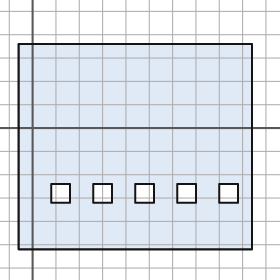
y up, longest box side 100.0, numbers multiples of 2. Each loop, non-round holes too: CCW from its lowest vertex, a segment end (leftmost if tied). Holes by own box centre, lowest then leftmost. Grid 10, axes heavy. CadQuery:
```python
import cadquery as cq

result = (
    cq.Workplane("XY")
    .moveTo(-6.0, -52.0)
    .lineTo(94.0, -52.0)
    .lineTo(94.0, 36.0)
    .lineTo(-6.0, 36.0)
    .close()
    .moveTo(8.0, -32.0)
    .lineTo(16.0, -32.0)
    .lineTo(16.0, -24.0)
    .lineTo(8.0, -24.0)
    .close()
    .moveTo(26.0, -32.0)
    .lineTo(34.0, -32.0)
    .lineTo(34.0, -24.0)
    .lineTo(26.0, -24.0)
    .close()
    .moveTo(44.0, -32.0)
    .lineTo(52.0, -32.0)
    .lineTo(52.0, -24.0)
    .lineTo(44.0, -24.0)
    .close()
    .moveTo(62.0, -32.0)
    .lineTo(70.0, -32.0)
    .lineTo(70.0, -24.0)
    .lineTo(62.0, -24.0)
    .close()
    .moveTo(80.0, -32.0)
    .lineTo(88.0, -32.0)
    .lineTo(88.0, -24.0)
    .lineTo(80.0, -24.0)
    .close()
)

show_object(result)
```